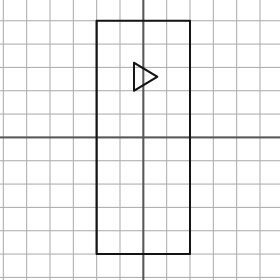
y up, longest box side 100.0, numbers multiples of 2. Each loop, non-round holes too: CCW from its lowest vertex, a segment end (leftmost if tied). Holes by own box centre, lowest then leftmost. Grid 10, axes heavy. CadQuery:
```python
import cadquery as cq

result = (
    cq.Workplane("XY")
    .moveTo(-20.0, -50.0)
    .lineTo(20.0, -50.0)
    .lineTo(20.0, 50.0)
    .lineTo(-20.0, 50.0)
    .close()
    .moveTo(-4.0, 20.0)
    .lineTo(6.0, 26.0)
    .lineTo(-4.0, 32.0)
    .close()
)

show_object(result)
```